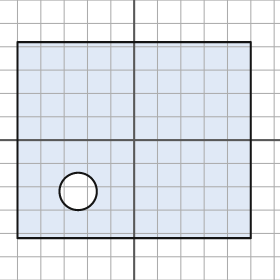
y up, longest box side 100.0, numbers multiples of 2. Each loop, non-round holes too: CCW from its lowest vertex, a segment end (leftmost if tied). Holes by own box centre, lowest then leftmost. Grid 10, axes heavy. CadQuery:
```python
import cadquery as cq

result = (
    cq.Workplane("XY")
    .moveTo(-50.0, -42.0)
    .lineTo(50.0, -42.0)
    .lineTo(50.0, 42.0)
    .lineTo(-50.0, 42.0)
    .close()
    .moveTo(-24.0, -22.0)
    .circle(8.0)
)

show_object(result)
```